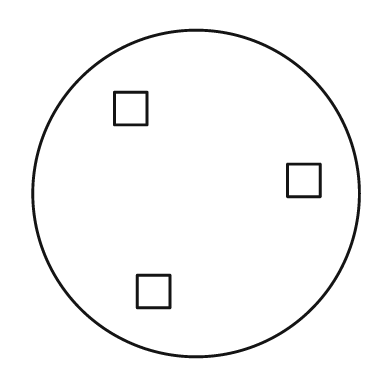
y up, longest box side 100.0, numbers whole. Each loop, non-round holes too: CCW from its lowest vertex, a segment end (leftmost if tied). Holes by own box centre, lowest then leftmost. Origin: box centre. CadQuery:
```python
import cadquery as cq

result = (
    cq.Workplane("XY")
    .moveTo(0.0, 0.0)
    .circle(50.0)
    .moveTo(-18.0, -35.0)
    .lineTo(-8.0, -35.0)
    .lineTo(-8.0, -25.0)
    .lineTo(-18.0, -25.0)
    .close()
    .moveTo(28.0, -1.0)
    .lineTo(38.0, -1.0)
    .lineTo(38.0, 9.0)
    .lineTo(28.0, 9.0)
    .close()
    .moveTo(-25.0, 21.0)
    .lineTo(-15.0, 21.0)
    .lineTo(-15.0, 31.0)
    .lineTo(-25.0, 31.0)
    .close()
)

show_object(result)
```